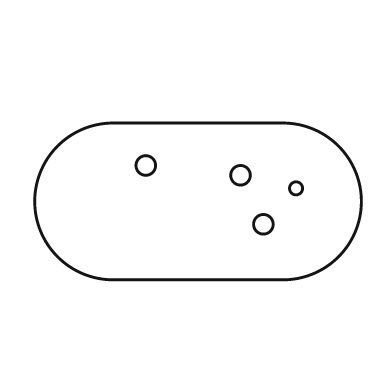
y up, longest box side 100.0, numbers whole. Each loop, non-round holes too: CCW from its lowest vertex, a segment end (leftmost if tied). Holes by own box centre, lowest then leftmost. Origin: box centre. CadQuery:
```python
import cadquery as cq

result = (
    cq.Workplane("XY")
    .moveTo(-26.0, -24.0)
    .lineTo(26.0, -24.0)
    .threePointArc((50.0, 0.0), (26.0, 24.0))
    .lineTo(-26.0, 24.0)
    .threePointArc((-50.0, 0.0), (-26.0, -24.0))
    .close()
    .moveTo(20.0, -7.0)
    .circle(3.0)
    .moveTo(30.0, 4.0)
    .circle(2.0)
    .moveTo(13.0, 8.0)
    .circle(3.0)
    .moveTo(-16.0, 11.0)
    .circle(3.0)
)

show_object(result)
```